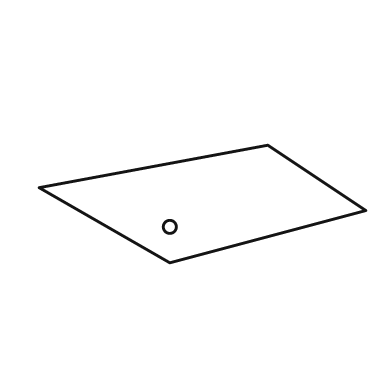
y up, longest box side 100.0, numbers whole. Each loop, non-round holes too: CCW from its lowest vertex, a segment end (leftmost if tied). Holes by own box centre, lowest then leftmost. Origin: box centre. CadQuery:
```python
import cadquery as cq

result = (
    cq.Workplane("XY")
    .moveTo(-10.0, -18.0)
    .lineTo(50.0, -2.0)
    .lineTo(20.0, 18.0)
    .lineTo(-50.0, 5.0)
    .close()
    .moveTo(-10.0, -7.0)
    .circle(2.0)
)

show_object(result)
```